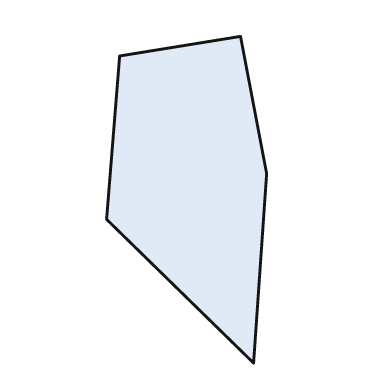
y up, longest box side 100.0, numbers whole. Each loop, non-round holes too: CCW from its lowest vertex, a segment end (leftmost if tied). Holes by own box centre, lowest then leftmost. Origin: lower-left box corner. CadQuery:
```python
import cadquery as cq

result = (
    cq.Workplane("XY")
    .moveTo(45.0, 0.0)
    .lineTo(49.0, 58.0)
    .lineTo(41.0, 100.0)
    .lineTo(4.0, 94.0)
    .lineTo(0.0, 44.0)
    .close()
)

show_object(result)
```